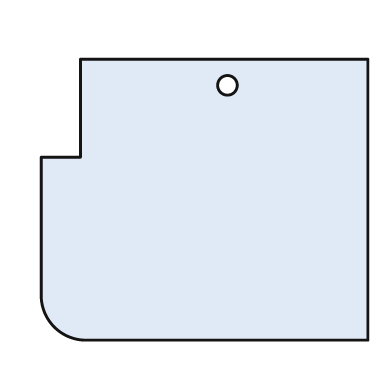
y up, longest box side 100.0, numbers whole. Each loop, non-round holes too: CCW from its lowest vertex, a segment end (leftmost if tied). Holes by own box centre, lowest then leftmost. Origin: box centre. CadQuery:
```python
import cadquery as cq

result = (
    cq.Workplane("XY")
    .moveTo(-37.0, -43.0)
    .lineTo(50.0, -43.0)
    .lineTo(50.0, 43.0)
    .lineTo(-38.0, 43.0)
    .lineTo(-38.0, 13.0)
    .lineTo(-50.0, 13.0)
    .lineTo(-50.0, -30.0)
    .threePointArc((-46.0, -39.0), (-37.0, -43.0))
    .close()
    .moveTo(7.0, 35.0)
    .circle(3.0)
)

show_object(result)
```